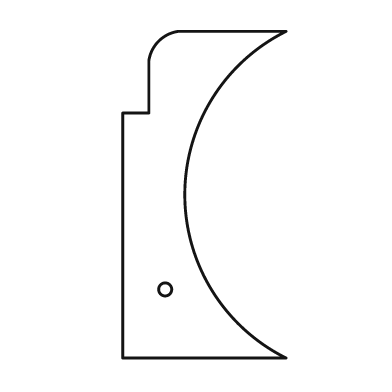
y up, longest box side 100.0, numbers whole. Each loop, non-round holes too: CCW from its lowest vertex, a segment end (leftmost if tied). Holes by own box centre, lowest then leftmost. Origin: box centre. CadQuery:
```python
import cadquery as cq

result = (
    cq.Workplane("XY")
    .moveTo(-25.0, -50.0)
    .lineTo(25.0, -50.0)
    .threePointArc((-6.0, 0.0), (25.0, 50.0))
    .lineTo(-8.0, 50.0)
    .threePointArc((-14.0, 47.0), (-17.0, 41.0))
    .lineTo(-17.0, 25.0)
    .lineTo(-25.0, 25.0)
    .close()
    .moveTo(-12.0, -29.0)
    .circle(2.0)
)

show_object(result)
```